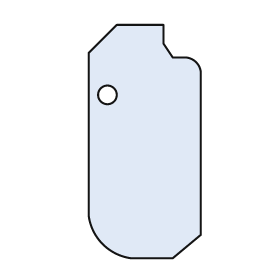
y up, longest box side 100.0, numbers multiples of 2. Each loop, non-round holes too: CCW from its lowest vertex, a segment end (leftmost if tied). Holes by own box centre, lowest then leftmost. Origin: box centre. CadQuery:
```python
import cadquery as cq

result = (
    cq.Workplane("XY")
    .moveTo(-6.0, -50.0)
    .lineTo(12.0, -50.0)
    .lineTo(24.0, -40.0)
    .lineTo(24.0, 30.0)
    .threePointArc((22.0, 34.0), (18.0, 36.0))
    .lineTo(12.0, 36.0)
    .lineTo(8.0, 42.0)
    .lineTo(8.0, 50.0)
    .lineTo(-12.0, 50.0)
    .lineTo(-24.0, 38.0)
    .lineTo(-24.0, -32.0)
    .threePointArc((-18.0, -44.0), (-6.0, -50.0))
    .close()
    .moveTo(-16.0, 20.0)
    .circle(4.0)
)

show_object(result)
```